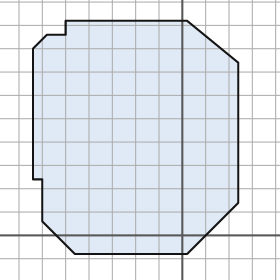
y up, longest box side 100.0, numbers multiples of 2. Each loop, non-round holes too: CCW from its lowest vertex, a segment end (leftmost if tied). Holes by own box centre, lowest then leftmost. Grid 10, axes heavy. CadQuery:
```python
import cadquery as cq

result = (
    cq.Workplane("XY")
    .moveTo(-46.0, -8.0)
    .lineTo(2.0, -8.0)
    .lineTo(24.0, 14.0)
    .lineTo(24.0, 74.0)
    .lineTo(2.0, 92.0)
    .lineTo(-50.0, 92.0)
    .lineTo(-50.0, 86.0)
    .lineTo(-58.0, 86.0)
    .lineTo(-64.0, 80.0)
    .lineTo(-64.0, 24.0)
    .lineTo(-60.0, 24.0)
    .lineTo(-60.0, 6.0)
    .close()
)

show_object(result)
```